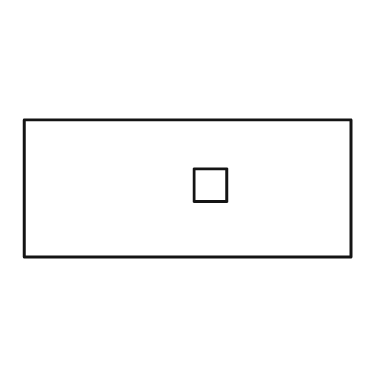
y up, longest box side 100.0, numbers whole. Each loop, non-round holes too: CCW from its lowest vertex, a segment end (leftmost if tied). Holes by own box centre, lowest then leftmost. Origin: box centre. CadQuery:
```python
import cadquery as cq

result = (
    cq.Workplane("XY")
    .moveTo(-50.0, -21.0)
    .lineTo(50.0, -21.0)
    .lineTo(50.0, 21.0)
    .lineTo(-50.0, 21.0)
    .close()
    .moveTo(2.0, -4.0)
    .lineTo(12.0, -4.0)
    .lineTo(12.0, 6.0)
    .lineTo(2.0, 6.0)
    .close()
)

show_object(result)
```